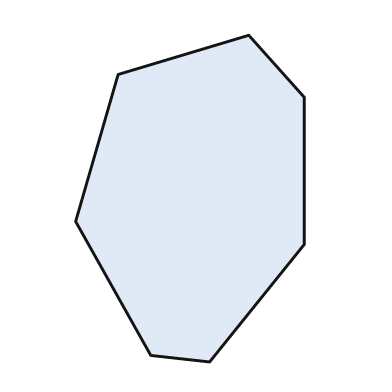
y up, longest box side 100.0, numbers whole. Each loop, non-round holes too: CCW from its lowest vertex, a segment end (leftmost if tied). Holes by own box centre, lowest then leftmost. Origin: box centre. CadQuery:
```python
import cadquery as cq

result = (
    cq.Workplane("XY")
    .moveTo(6.0, -50.0)
    .lineTo(35.0, -14.0)
    .lineTo(35.0, 31.0)
    .lineTo(18.0, 50.0)
    .lineTo(-22.0, 38.0)
    .lineTo(-35.0, -7.0)
    .lineTo(-12.0, -48.0)
    .close()
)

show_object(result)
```